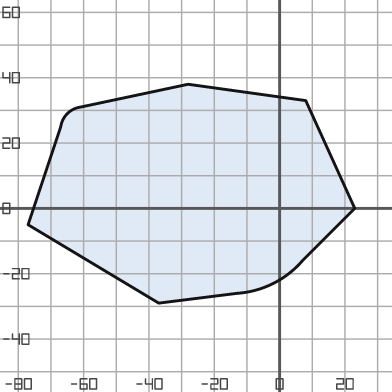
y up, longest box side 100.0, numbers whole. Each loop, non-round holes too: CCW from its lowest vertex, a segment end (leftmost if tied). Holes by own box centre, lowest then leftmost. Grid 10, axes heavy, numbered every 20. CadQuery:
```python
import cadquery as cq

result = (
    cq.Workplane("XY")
    .moveTo(-37.0, -29.0)
    .lineTo(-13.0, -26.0)
    .threePointArc((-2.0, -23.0), (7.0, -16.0))
    .lineTo(23.0, 0.0)
    .lineTo(8.0, 33.0)
    .lineTo(-28.0, 38.0)
    .lineTo(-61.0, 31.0)
    .threePointArc((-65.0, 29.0), (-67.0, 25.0))
    .lineTo(-77.0, -5.0)
    .close()
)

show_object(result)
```